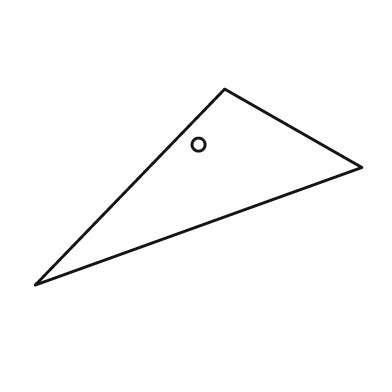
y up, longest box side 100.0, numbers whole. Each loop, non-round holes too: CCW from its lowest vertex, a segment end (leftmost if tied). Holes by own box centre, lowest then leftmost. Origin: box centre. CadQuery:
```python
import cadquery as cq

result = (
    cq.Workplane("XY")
    .moveTo(-50.0, -30.0)
    .lineTo(50.0, 6.0)
    .lineTo(8.0, 30.0)
    .close()
    .moveTo(0.0, 13.0)
    .circle(2.0)
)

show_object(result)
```